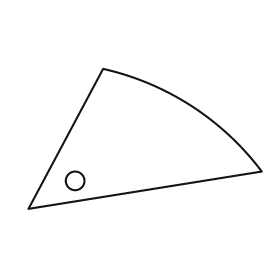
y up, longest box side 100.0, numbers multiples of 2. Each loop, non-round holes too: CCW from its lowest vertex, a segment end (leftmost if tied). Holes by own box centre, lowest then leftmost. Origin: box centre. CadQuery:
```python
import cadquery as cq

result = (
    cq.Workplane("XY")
    .moveTo(-50.0, -30.0)
    .lineTo(50.0, -14.0)
    .threePointArc((20.0, 14.0), (-18.0, 30.0))
    .close()
    .moveTo(-30.0, -18.0)
    .circle(4.0)
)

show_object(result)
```